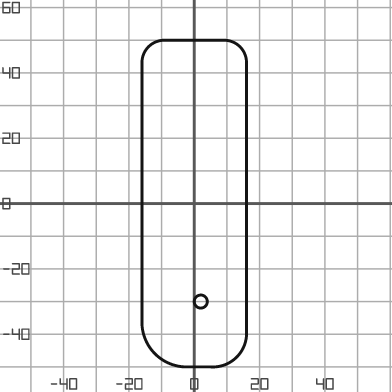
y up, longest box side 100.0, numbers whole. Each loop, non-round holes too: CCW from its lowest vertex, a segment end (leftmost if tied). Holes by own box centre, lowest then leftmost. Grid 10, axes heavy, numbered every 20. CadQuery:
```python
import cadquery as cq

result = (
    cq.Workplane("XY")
    .moveTo(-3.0, -50.0)
    .lineTo(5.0, -50.0)
    .threePointArc((13.0, -47.0), (16.0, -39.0))
    .lineTo(16.0, 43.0)
    .threePointArc((14.0, 48.0), (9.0, 50.0))
    .lineTo(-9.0, 50.0)
    .threePointArc((-14.0, 48.0), (-16.0, 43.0))
    .lineTo(-16.0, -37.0)
    .threePointArc((-12.0, -46.0), (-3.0, -50.0))
    .close()
    .moveTo(2.0, -30.0)
    .circle(2.0)
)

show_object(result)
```